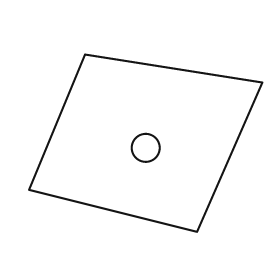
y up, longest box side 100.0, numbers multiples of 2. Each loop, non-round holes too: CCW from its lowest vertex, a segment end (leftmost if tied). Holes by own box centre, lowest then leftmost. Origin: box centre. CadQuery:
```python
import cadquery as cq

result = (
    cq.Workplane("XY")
    .moveTo(22.0, -38.0)
    .lineTo(50.0, 26.0)
    .lineTo(-26.0, 38.0)
    .lineTo(-50.0, -20.0)
    .close()
    .moveTo(0.0, -2.0)
    .circle(6.0)
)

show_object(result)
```